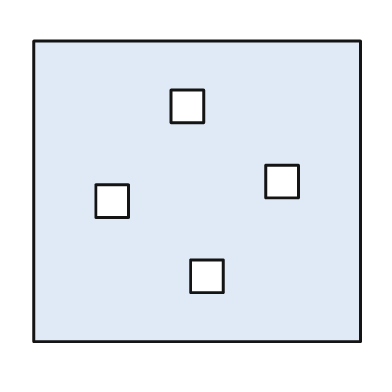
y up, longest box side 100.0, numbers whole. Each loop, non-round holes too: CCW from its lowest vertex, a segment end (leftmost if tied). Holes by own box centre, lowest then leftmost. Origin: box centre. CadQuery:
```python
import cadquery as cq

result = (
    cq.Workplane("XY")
    .moveTo(-50.0, -46.0)
    .lineTo(50.0, -46.0)
    .lineTo(50.0, 46.0)
    .lineTo(-50.0, 46.0)
    .close()
    .moveTo(-2.0, -31.0)
    .lineTo(8.0, -31.0)
    .lineTo(8.0, -21.0)
    .lineTo(-2.0, -21.0)
    .close()
    .moveTo(-31.0, -8.0)
    .lineTo(-21.0, -8.0)
    .lineTo(-21.0, 2.0)
    .lineTo(-31.0, 2.0)
    .close()
    .moveTo(21.0, -2.0)
    .lineTo(31.0, -2.0)
    .lineTo(31.0, 8.0)
    .lineTo(21.0, 8.0)
    .close()
    .moveTo(-8.0, 21.0)
    .lineTo(2.0, 21.0)
    .lineTo(2.0, 31.0)
    .lineTo(-8.0, 31.0)
    .close()
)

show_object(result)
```